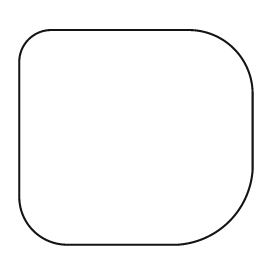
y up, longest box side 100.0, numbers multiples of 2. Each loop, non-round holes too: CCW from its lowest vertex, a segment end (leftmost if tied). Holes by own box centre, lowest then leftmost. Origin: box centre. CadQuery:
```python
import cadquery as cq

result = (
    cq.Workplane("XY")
    .moveTo(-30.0, -46.0)
    .lineTo(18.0, -46.0)
    .threePointArc((40.0, -36.0), (50.0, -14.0))
    .lineTo(50.0, 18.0)
    .threePointArc((42.0, 38.0), (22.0, 46.0))
    .lineTo(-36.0, 46.0)
    .threePointArc((-46.0, 42.0), (-50.0, 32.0))
    .lineTo(-50.0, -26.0)
    .threePointArc((-44.0, -40.0), (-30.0, -46.0))
    .close()
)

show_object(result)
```